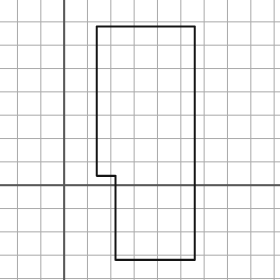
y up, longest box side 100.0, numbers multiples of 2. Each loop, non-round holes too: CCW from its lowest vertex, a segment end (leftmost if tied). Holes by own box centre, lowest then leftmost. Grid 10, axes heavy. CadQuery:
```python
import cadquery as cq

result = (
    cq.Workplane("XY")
    .moveTo(22.0, -32.0)
    .lineTo(56.0, -32.0)
    .lineTo(56.0, 68.0)
    .lineTo(14.0, 68.0)
    .lineTo(14.0, 4.0)
    .lineTo(22.0, 4.0)
    .close()
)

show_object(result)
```